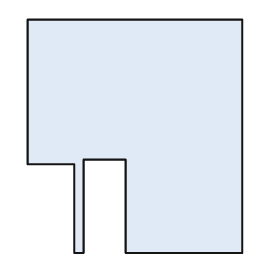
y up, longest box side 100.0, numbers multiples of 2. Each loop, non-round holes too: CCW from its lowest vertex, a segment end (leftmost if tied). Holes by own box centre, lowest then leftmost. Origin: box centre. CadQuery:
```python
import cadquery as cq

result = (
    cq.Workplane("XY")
    .moveTo(-26.0, -50.0)
    .lineTo(-22.0, -50.0)
    .lineTo(-22.0, -10.0)
    .lineTo(-4.0, -10.0)
    .lineTo(-4.0, -50.0)
    .lineTo(46.0, -50.0)
    .lineTo(46.0, 50.0)
    .lineTo(-46.0, 50.0)
    .lineTo(-46.0, -12.0)
    .lineTo(-26.0, -12.0)
    .close()
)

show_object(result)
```